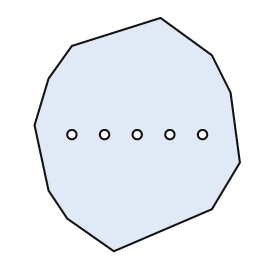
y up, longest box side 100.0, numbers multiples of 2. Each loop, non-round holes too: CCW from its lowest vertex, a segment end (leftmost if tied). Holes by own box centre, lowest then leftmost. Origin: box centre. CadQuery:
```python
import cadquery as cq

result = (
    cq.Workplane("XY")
    .moveTo(-10.0, -50.0)
    .lineTo(32.0, -32.0)
    .lineTo(44.0, -12.0)
    .lineTo(40.0, 18.0)
    .lineTo(32.0, 34.0)
    .lineTo(10.0, 50.0)
    .lineTo(-28.0, 38.0)
    .lineTo(-38.0, 24.0)
    .lineTo(-44.0, 4.0)
    .lineTo(-38.0, -24.0)
    .lineTo(-30.0, -36.0)
    .close()
    .moveTo(-28.0, 0.0)
    .circle(2.0)
    .moveTo(-14.0, 0.0)
    .circle(2.0)
    .moveTo(0.0, 0.0)
    .circle(2.0)
    .moveTo(14.0, 0.0)
    .circle(2.0)
    .moveTo(28.0, 0.0)
    .circle(2.0)
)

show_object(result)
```